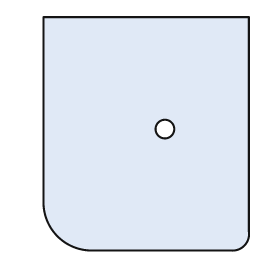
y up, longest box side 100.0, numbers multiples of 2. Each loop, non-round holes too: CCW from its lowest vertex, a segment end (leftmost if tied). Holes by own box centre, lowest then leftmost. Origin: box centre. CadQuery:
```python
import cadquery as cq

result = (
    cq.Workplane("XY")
    .moveTo(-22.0, -50.0)
    .lineTo(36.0, -50.0)
    .threePointArc((42.0, -48.0), (44.0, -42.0))
    .lineTo(44.0, 50.0)
    .lineTo(-44.0, 50.0)
    .lineTo(-44.0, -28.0)
    .threePointArc((-38.0, -44.0), (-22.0, -50.0))
    .close()
    .moveTo(8.0, 2.0)
    .circle(4.0)
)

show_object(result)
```